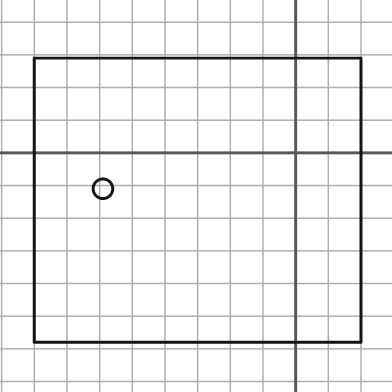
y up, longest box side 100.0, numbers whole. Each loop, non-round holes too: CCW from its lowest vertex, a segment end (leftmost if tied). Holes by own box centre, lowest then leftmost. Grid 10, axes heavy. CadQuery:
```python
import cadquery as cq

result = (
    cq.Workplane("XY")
    .moveTo(-80.0, -58.0)
    .lineTo(20.0, -58.0)
    .lineTo(20.0, 29.0)
    .lineTo(-80.0, 29.0)
    .close()
    .moveTo(-59.0, -11.0)
    .circle(3.0)
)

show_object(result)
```